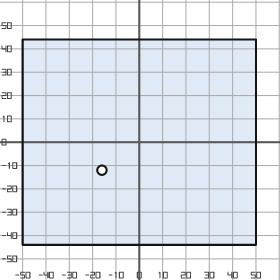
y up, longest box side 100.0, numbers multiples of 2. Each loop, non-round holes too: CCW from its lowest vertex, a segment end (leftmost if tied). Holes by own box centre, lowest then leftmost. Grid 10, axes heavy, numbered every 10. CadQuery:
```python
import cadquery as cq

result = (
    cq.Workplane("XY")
    .moveTo(-50.0, -44.0)
    .lineTo(50.0, -44.0)
    .lineTo(50.0, 44.0)
    .lineTo(-50.0, 44.0)
    .close()
    .moveTo(-16.0, -12.0)
    .circle(2.0)
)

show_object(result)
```